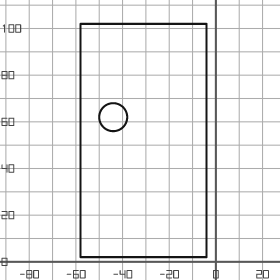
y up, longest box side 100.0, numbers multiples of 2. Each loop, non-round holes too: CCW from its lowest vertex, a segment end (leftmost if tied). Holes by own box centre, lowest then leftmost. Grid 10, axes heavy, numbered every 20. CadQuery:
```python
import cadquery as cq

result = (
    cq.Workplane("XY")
    .moveTo(-58.0, 2.0)
    .lineTo(-4.0, 2.0)
    .lineTo(-4.0, 102.0)
    .lineTo(-58.0, 102.0)
    .close()
    .moveTo(-44.0, 62.0)
    .circle(6.0)
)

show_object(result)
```